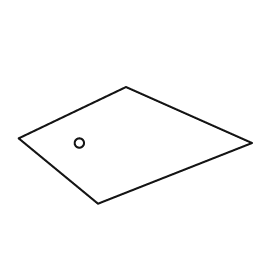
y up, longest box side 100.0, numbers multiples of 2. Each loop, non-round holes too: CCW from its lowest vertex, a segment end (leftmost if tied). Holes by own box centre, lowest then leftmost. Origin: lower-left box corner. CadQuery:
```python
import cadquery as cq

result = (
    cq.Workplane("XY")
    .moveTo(34.0, 0.0)
    .lineTo(100.0, 26.0)
    .lineTo(46.0, 50.0)
    .lineTo(0.0, 28.0)
    .close()
    .moveTo(26.0, 26.0)
    .circle(2.0)
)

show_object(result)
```